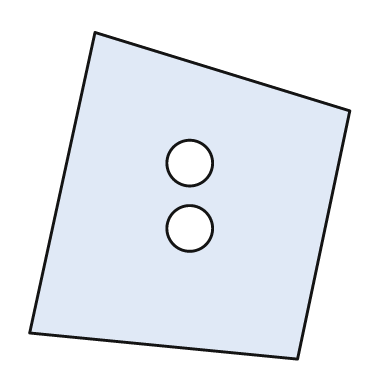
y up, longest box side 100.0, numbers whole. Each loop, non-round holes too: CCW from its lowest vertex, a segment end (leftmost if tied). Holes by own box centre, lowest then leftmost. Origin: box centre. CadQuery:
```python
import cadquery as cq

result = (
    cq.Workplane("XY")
    .moveTo(33.0, -50.0)
    .lineTo(49.0, 26.0)
    .lineTo(-29.0, 50.0)
    .lineTo(-49.0, -42.0)
    .close()
    .moveTo(0.0, -10.0)
    .circle(7.0)
    .moveTo(0.0, 10.0)
    .circle(7.0)
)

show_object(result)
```